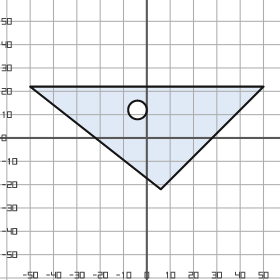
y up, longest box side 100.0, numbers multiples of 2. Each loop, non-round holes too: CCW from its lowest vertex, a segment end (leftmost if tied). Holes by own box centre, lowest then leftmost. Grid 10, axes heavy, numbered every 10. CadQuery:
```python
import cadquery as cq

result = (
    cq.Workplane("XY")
    .moveTo(6.0, -22.0)
    .lineTo(50.0, 22.0)
    .lineTo(-50.0, 22.0)
    .close()
    .moveTo(-4.0, 12.0)
    .circle(4.0)
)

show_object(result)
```